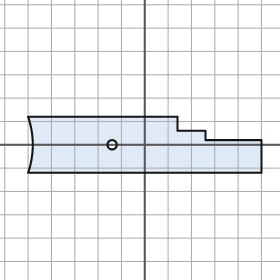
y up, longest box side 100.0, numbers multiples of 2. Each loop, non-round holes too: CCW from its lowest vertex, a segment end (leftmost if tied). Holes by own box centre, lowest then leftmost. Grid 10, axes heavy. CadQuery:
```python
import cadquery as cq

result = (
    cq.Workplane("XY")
    .moveTo(-50.0, -12.0)
    .lineTo(50.0, -12.0)
    .lineTo(50.0, 2.0)
    .lineTo(26.0, 2.0)
    .lineTo(26.0, 6.0)
    .lineTo(14.0, 6.0)
    .lineTo(14.0, 12.0)
    .lineTo(-50.0, 12.0)
    .threePointArc((-48.0, 0.0), (-50.0, -12.0))
    .close()
    .moveTo(-14.0, 0.0)
    .circle(2.0)
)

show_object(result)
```